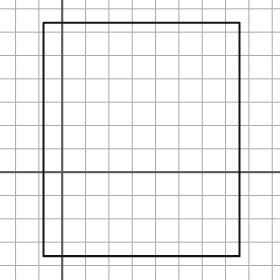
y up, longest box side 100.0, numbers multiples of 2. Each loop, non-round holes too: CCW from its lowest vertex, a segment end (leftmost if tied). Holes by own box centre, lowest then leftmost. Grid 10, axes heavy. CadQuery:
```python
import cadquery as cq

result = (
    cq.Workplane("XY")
    .moveTo(-8.0, -36.0)
    .lineTo(76.0, -36.0)
    .lineTo(76.0, 64.0)
    .lineTo(-8.0, 64.0)
    .close()
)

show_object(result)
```